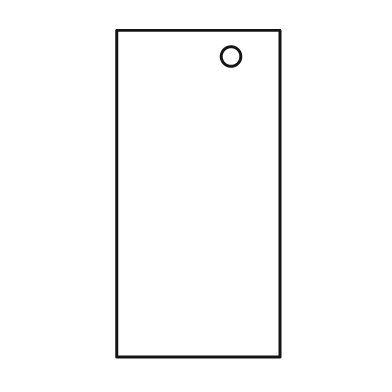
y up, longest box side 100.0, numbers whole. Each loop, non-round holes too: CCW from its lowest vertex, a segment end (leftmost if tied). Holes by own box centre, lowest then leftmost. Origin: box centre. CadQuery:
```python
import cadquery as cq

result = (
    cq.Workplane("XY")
    .moveTo(-25.0, -50.0)
    .lineTo(25.0, -50.0)
    .lineTo(25.0, 50.0)
    .lineTo(-25.0, 50.0)
    .close()
    .moveTo(10.0, 42.0)
    .circle(3.0)
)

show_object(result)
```